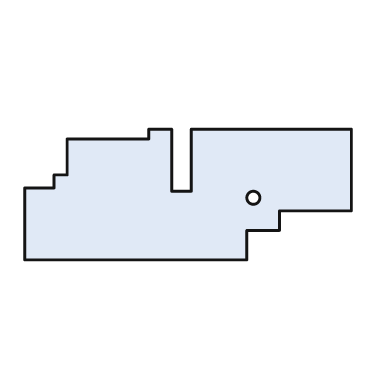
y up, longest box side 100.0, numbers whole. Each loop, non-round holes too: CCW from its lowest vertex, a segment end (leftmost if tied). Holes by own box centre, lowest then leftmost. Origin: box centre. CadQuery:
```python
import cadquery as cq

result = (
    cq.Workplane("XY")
    .moveTo(-50.0, -20.0)
    .lineTo(18.0, -20.0)
    .lineTo(18.0, -11.0)
    .lineTo(28.0, -11.0)
    .lineTo(28.0, -5.0)
    .lineTo(50.0, -5.0)
    .lineTo(50.0, 20.0)
    .lineTo(1.0, 20.0)
    .lineTo(1.0, 1.0)
    .lineTo(-5.0, 1.0)
    .lineTo(-5.0, 20.0)
    .lineTo(-12.0, 20.0)
    .lineTo(-12.0, 17.0)
    .lineTo(-37.0, 17.0)
    .lineTo(-37.0, 6.0)
    .lineTo(-41.0, 6.0)
    .lineTo(-41.0, 2.0)
    .lineTo(-50.0, 2.0)
    .close()
    .moveTo(20.0, -1.0)
    .circle(2.0)
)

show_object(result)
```